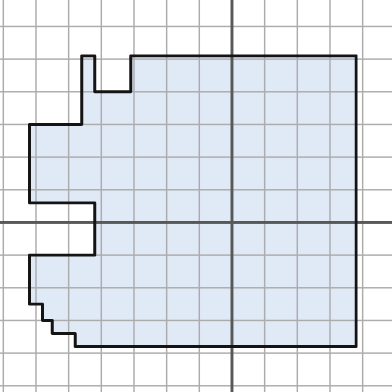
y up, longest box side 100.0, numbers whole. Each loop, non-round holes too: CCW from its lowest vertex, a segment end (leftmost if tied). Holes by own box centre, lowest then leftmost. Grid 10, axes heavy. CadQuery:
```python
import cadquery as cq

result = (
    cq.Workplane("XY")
    .moveTo(-48.0, -38.0)
    .lineTo(38.0, -38.0)
    .lineTo(38.0, 51.0)
    .lineTo(-31.0, 51.0)
    .lineTo(-31.0, 40.0)
    .lineTo(-42.0, 40.0)
    .lineTo(-42.0, 51.0)
    .lineTo(-46.0, 51.0)
    .lineTo(-46.0, 30.0)
    .lineTo(-62.0, 30.0)
    .lineTo(-62.0, 6.0)
    .lineTo(-42.0, 6.0)
    .lineTo(-42.0, -10.0)
    .lineTo(-62.0, -10.0)
    .lineTo(-62.0, -25.0)
    .lineTo(-58.0, -25.0)
    .lineTo(-58.0, -30.0)
    .lineTo(-55.0, -30.0)
    .lineTo(-55.0, -34.0)
    .lineTo(-48.0, -34.0)
    .close()
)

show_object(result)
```